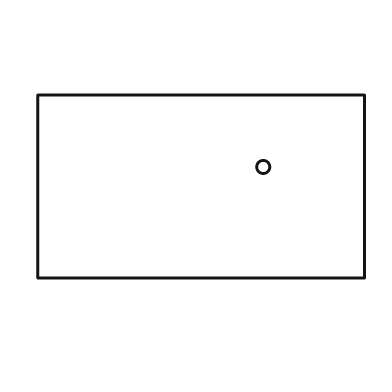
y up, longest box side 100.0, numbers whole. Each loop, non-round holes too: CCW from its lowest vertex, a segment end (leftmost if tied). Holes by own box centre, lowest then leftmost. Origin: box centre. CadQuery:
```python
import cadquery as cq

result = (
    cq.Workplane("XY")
    .moveTo(-50.0, -28.0)
    .lineTo(50.0, -28.0)
    .lineTo(50.0, 28.0)
    .lineTo(-50.0, 28.0)
    .close()
    .moveTo(19.0, 6.0)
    .circle(2.0)
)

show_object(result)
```